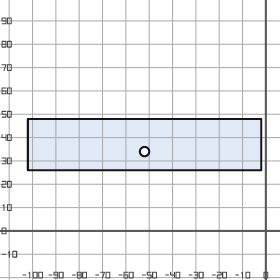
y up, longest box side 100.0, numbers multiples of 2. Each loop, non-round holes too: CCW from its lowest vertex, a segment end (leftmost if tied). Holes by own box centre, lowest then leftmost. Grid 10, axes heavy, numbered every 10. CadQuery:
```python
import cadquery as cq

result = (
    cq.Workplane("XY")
    .moveTo(-102.0, 26.0)
    .lineTo(-2.0, 26.0)
    .lineTo(-2.0, 48.0)
    .lineTo(-102.0, 48.0)
    .close()
    .moveTo(-52.0, 34.0)
    .circle(2.0)
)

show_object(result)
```